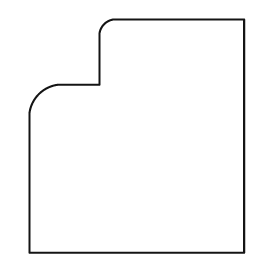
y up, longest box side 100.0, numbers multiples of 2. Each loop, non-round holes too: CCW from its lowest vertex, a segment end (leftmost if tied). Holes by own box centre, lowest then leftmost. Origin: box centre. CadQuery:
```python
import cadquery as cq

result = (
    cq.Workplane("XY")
    .moveTo(-46.0, -50.0)
    .lineTo(46.0, -50.0)
    .lineTo(46.0, 50.0)
    .lineTo(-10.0, 50.0)
    .threePointArc((-14.0, 48.0), (-16.0, 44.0))
    .lineTo(-16.0, 22.0)
    .lineTo(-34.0, 22.0)
    .threePointArc((-42.0, 18.0), (-46.0, 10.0))
    .close()
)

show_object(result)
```